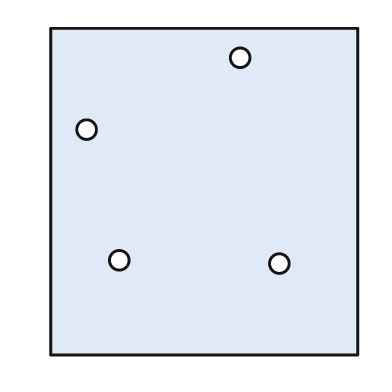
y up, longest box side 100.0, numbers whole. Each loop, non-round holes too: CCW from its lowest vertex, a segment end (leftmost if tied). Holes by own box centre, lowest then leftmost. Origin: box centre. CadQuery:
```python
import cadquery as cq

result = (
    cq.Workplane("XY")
    .moveTo(-47.0, -50.0)
    .lineTo(47.0, -50.0)
    .lineTo(47.0, 50.0)
    .lineTo(-47.0, 50.0)
    .close()
    .moveTo(23.0, -22.0)
    .circle(3.0)
    .moveTo(-26.0, -21.0)
    .circle(3.0)
    .moveTo(-36.0, 19.0)
    .circle(3.0)
    .moveTo(11.0, 41.0)
    .circle(3.0)
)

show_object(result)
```